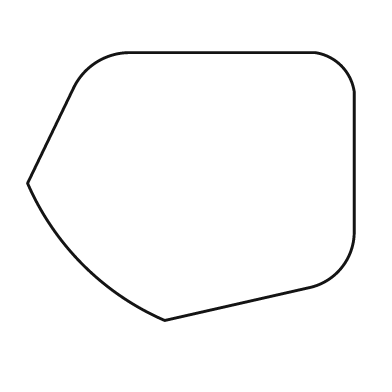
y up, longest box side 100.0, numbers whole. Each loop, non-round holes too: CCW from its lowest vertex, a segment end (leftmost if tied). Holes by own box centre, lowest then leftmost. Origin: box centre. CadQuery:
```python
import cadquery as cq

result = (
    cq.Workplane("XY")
    .moveTo(-8.0, -41.0)
    .lineTo(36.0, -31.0)
    .threePointArc((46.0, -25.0), (50.0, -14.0))
    .lineTo(50.0, 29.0)
    .threePointArc((46.0, 37.0), (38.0, 41.0))
    .lineTo(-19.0, 41.0)
    .threePointArc((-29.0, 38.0), (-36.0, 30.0))
    .lineTo(-50.0, 1.0)
    .threePointArc((-33.0, -24.0), (-8.0, -41.0))
    .close()
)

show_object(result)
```